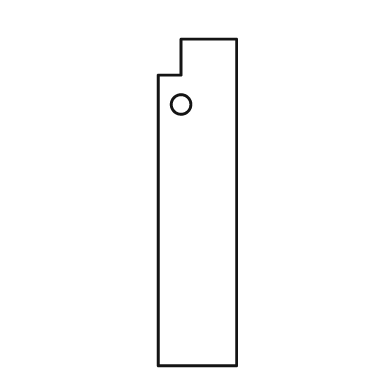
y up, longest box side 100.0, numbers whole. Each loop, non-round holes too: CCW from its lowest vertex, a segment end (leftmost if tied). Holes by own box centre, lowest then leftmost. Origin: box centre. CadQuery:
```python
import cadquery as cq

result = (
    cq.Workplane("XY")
    .moveTo(-12.0, -50.0)
    .lineTo(12.0, -50.0)
    .lineTo(12.0, 50.0)
    .lineTo(-5.0, 50.0)
    .lineTo(-5.0, 39.0)
    .lineTo(-12.0, 39.0)
    .close()
    .moveTo(-5.0, 30.0)
    .circle(3.0)
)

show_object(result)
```